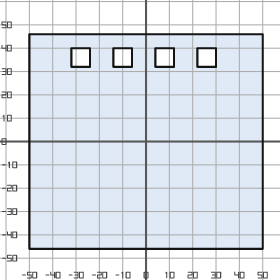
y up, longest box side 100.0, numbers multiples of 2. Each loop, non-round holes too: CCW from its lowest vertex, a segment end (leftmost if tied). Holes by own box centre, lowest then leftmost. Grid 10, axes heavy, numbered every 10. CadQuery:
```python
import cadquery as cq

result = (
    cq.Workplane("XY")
    .moveTo(-50.0, -46.0)
    .lineTo(50.0, -46.0)
    .lineTo(50.0, 46.0)
    .lineTo(-50.0, 46.0)
    .close()
    .moveTo(-32.0, 32.0)
    .lineTo(-24.0, 32.0)
    .lineTo(-24.0, 40.0)
    .lineTo(-32.0, 40.0)
    .close()
    .moveTo(-14.0, 32.0)
    .lineTo(-6.0, 32.0)
    .lineTo(-6.0, 40.0)
    .lineTo(-14.0, 40.0)
    .close()
    .moveTo(4.0, 32.0)
    .lineTo(12.0, 32.0)
    .lineTo(12.0, 40.0)
    .lineTo(4.0, 40.0)
    .close()
    .moveTo(22.0, 32.0)
    .lineTo(30.0, 32.0)
    .lineTo(30.0, 40.0)
    .lineTo(22.0, 40.0)
    .close()
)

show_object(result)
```